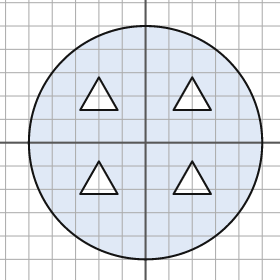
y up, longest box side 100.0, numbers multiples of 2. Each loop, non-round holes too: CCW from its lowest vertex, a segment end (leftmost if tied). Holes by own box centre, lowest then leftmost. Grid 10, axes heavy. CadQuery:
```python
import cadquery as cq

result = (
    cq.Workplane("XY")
    .moveTo(0.0, 0.0)
    .circle(50.0)
    .moveTo(-28.0, -22.0)
    .lineTo(-12.0, -22.0)
    .lineTo(-20.0, -8.0)
    .close()
    .moveTo(12.0, -22.0)
    .lineTo(28.0, -22.0)
    .lineTo(20.0, -8.0)
    .close()
    .moveTo(-28.0, 14.0)
    .lineTo(-12.0, 14.0)
    .lineTo(-20.0, 28.0)
    .close()
    .moveTo(12.0, 14.0)
    .lineTo(28.0, 14.0)
    .lineTo(20.0, 28.0)
    .close()
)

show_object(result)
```